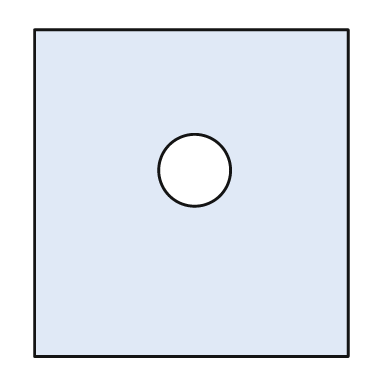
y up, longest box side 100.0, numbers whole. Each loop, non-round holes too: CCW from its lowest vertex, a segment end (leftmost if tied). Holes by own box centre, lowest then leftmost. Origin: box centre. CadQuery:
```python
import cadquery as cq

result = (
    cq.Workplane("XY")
    .moveTo(-48.0, -50.0)
    .lineTo(48.0, -50.0)
    .lineTo(48.0, 50.0)
    .lineTo(-48.0, 50.0)
    .close()
    .moveTo(1.0, 7.0)
    .circle(11.0)
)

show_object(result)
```